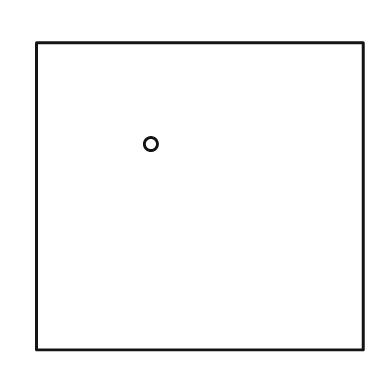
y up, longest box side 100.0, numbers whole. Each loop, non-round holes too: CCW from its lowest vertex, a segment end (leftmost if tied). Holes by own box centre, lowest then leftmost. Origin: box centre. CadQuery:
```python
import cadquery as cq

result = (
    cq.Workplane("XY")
    .moveTo(-50.0, -47.0)
    .lineTo(50.0, -47.0)
    .lineTo(50.0, 47.0)
    .lineTo(-50.0, 47.0)
    .close()
    .moveTo(-15.0, 16.0)
    .circle(2.0)
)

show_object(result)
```